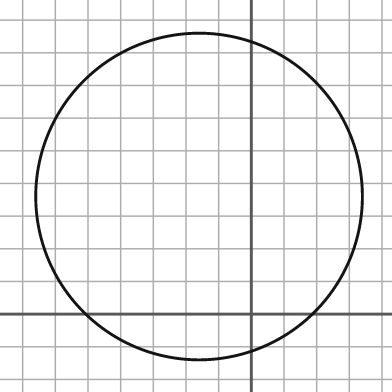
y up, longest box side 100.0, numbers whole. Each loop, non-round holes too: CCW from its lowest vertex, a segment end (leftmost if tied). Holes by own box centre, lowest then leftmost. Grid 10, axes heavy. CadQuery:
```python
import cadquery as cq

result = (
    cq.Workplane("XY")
    .moveTo(-16.0, 36.0)
    .circle(50.0)
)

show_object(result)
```